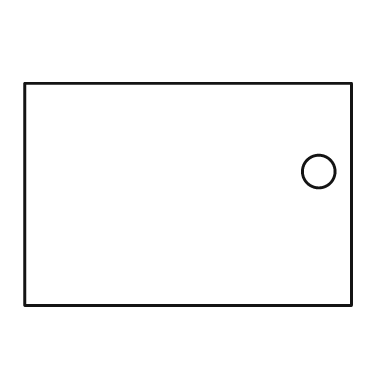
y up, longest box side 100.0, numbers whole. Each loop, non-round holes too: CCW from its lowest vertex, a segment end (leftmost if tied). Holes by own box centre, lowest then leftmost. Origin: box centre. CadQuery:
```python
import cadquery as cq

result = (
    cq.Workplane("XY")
    .moveTo(-50.0, -34.0)
    .lineTo(50.0, -34.0)
    .lineTo(50.0, 34.0)
    .lineTo(-50.0, 34.0)
    .close()
    .moveTo(40.0, 7.0)
    .circle(5.0)
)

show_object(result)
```